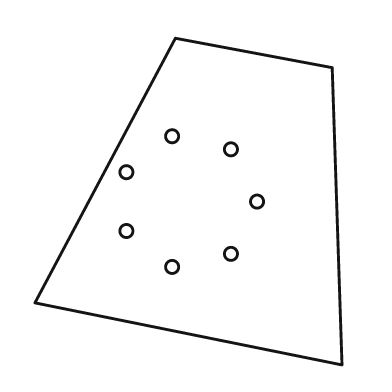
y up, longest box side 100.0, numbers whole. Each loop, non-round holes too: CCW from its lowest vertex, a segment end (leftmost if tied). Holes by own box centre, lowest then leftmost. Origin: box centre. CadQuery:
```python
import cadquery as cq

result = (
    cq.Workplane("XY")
    .moveTo(47.0, -50.0)
    .lineTo(44.0, 41.0)
    .lineTo(-4.0, 50.0)
    .lineTo(-47.0, -31.0)
    .close()
    .moveTo(-5.0, -20.0)
    .circle(2.0)
    .moveTo(13.0, -16.0)
    .circle(2.0)
    .moveTo(-19.0, -9.0)
    .circle(2.0)
    .moveTo(21.0, 0.0)
    .circle(2.0)
    .moveTo(-19.0, 9.0)
    .circle(2.0)
    .moveTo(13.0, 16.0)
    .circle(2.0)
    .moveTo(-5.0, 20.0)
    .circle(2.0)
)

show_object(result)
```